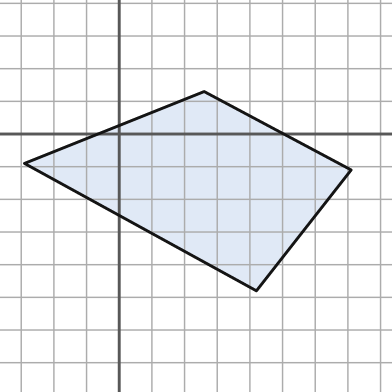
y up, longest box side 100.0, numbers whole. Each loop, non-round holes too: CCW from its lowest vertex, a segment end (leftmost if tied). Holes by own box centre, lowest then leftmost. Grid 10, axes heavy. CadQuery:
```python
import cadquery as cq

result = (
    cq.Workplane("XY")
    .moveTo(42.0, -48.0)
    .lineTo(71.0, -11.0)
    .lineTo(26.0, 13.0)
    .lineTo(-29.0, -9.0)
    .close()
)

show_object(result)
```